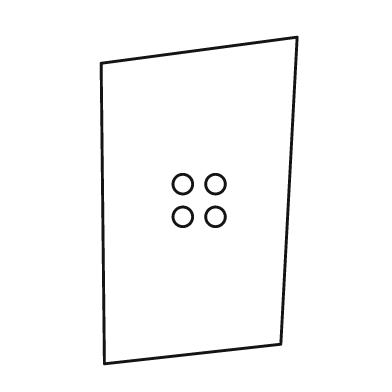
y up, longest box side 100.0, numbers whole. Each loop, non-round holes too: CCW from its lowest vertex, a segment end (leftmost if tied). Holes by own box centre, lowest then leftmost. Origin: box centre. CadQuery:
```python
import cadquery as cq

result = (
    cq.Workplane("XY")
    .moveTo(-29.0, -50.0)
    .lineTo(25.0, -44.0)
    .lineTo(30.0, 50.0)
    .lineTo(-30.0, 42.0)
    .close()
    .moveTo(-5.0, -5.0)
    .circle(3.0)
    .moveTo(5.0, -5.0)
    .circle(3.0)
    .moveTo(-5.0, 5.0)
    .circle(3.0)
    .moveTo(5.0, 5.0)
    .circle(3.0)
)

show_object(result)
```